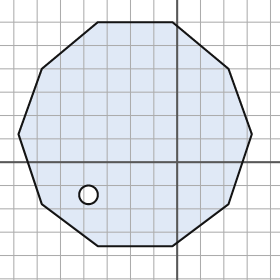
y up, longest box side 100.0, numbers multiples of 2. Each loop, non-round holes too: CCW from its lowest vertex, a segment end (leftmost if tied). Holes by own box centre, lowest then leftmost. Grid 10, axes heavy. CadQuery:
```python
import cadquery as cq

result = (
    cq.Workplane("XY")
    .moveTo(-34.0, -36.0)
    .lineTo(-2.0, -36.0)
    .lineTo(22.0, -18.0)
    .lineTo(32.0, 12.0)
    .lineTo(22.0, 40.0)
    .lineTo(-2.0, 60.0)
    .lineTo(-34.0, 60.0)
    .lineTo(-58.0, 40.0)
    .lineTo(-68.0, 12.0)
    .lineTo(-58.0, -18.0)
    .close()
    .moveTo(-38.0, -14.0)
    .circle(4.0)
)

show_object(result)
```